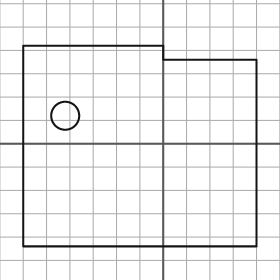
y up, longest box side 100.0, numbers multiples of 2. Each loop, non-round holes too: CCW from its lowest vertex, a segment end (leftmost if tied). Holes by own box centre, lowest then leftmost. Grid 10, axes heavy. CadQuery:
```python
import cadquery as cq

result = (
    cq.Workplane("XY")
    .moveTo(-60.0, -44.0)
    .lineTo(40.0, -44.0)
    .lineTo(40.0, 36.0)
    .lineTo(0.0, 36.0)
    .lineTo(0.0, 42.0)
    .lineTo(-60.0, 42.0)
    .close()
    .moveTo(-42.0, 12.0)
    .circle(6.0)
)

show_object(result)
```